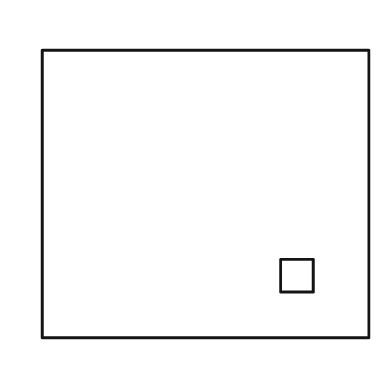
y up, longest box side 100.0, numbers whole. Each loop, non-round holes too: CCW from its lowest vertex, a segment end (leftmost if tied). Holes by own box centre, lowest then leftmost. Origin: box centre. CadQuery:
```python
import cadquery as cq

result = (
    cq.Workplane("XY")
    .moveTo(-50.0, -44.0)
    .lineTo(50.0, -44.0)
    .lineTo(50.0, 44.0)
    .lineTo(-50.0, 44.0)
    .close()
    .moveTo(23.0, -30.0)
    .lineTo(33.0, -30.0)
    .lineTo(33.0, -20.0)
    .lineTo(23.0, -20.0)
    .close()
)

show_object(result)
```